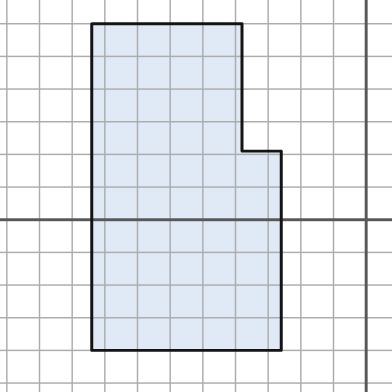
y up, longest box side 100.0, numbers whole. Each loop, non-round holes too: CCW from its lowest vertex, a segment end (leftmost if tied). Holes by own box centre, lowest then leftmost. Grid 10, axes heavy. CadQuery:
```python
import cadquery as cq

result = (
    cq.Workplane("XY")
    .moveTo(-84.0, -40.0)
    .lineTo(-26.0, -40.0)
    .lineTo(-26.0, 21.0)
    .lineTo(-38.0, 21.0)
    .lineTo(-38.0, 60.0)
    .lineTo(-84.0, 60.0)
    .close()
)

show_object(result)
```